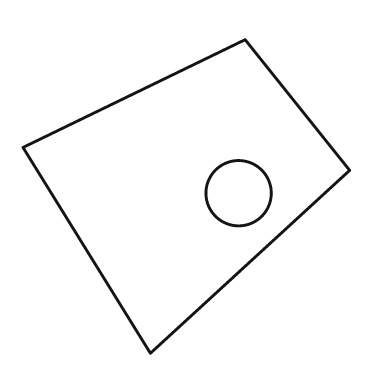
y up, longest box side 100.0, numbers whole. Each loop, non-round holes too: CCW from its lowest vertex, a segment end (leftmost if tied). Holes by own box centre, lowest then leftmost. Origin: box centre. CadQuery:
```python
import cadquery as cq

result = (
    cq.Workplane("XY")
    .moveTo(-11.0, -48.0)
    .lineTo(50.0, 8.0)
    .lineTo(18.0, 48.0)
    .lineTo(-50.0, 15.0)
    .close()
    .moveTo(16.0, 1.0)
    .circle(10.0)
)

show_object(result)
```